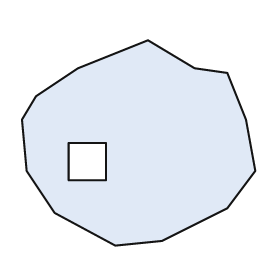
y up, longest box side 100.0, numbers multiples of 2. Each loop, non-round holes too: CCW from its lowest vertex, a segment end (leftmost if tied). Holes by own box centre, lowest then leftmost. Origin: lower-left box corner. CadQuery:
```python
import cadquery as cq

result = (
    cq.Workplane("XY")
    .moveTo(40.0, 0.0)
    .lineTo(60.0, 2.0)
    .lineTo(88.0, 16.0)
    .lineTo(100.0, 32.0)
    .lineTo(96.0, 54.0)
    .lineTo(88.0, 74.0)
    .lineTo(74.0, 76.0)
    .lineTo(54.0, 88.0)
    .lineTo(24.0, 76.0)
    .lineTo(6.0, 64.0)
    .lineTo(0.0, 54.0)
    .lineTo(2.0, 32.0)
    .lineTo(14.0, 14.0)
    .close()
    .moveTo(20.0, 28.0)
    .lineTo(36.0, 28.0)
    .lineTo(36.0, 44.0)
    .lineTo(20.0, 44.0)
    .close()
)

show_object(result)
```